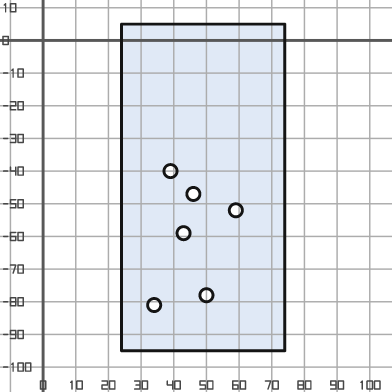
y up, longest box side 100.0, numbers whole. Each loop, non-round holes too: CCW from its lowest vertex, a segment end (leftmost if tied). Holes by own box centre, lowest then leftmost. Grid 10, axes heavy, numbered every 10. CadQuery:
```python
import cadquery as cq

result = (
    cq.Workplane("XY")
    .moveTo(24.0, -95.0)
    .lineTo(74.0, -95.0)
    .lineTo(74.0, 5.0)
    .lineTo(24.0, 5.0)
    .close()
    .moveTo(34.0, -81.0)
    .circle(2.0)
    .moveTo(50.0, -78.0)
    .circle(2.0)
    .moveTo(43.0, -59.0)
    .circle(2.0)
    .moveTo(59.0, -52.0)
    .circle(2.0)
    .moveTo(46.0, -47.0)
    .circle(2.0)
    .moveTo(39.0, -40.0)
    .circle(2.0)
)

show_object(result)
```